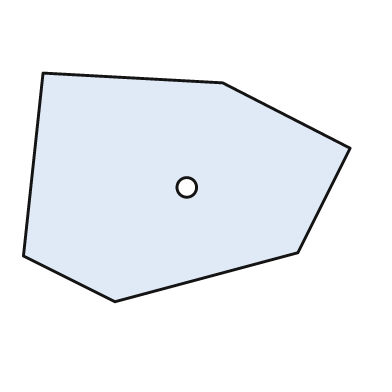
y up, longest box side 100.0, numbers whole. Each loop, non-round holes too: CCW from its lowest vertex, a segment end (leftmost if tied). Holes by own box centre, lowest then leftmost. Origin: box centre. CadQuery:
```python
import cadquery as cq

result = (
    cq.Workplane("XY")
    .moveTo(-22.0, -35.0)
    .lineTo(34.0, -20.0)
    .lineTo(50.0, 12.0)
    .lineTo(11.0, 32.0)
    .lineTo(-44.0, 35.0)
    .lineTo(-50.0, -21.0)
    .close()
    .moveTo(0.0, 0.0)
    .circle(3.0)
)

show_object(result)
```